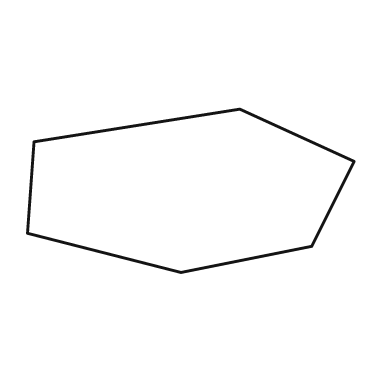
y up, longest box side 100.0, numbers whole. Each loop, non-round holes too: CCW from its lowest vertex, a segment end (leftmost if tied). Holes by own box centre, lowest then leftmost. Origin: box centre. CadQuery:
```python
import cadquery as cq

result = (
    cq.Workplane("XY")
    .moveTo(-3.0, -25.0)
    .lineTo(37.0, -17.0)
    .lineTo(50.0, 9.0)
    .lineTo(15.0, 25.0)
    .lineTo(-48.0, 15.0)
    .lineTo(-50.0, -13.0)
    .close()
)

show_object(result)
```